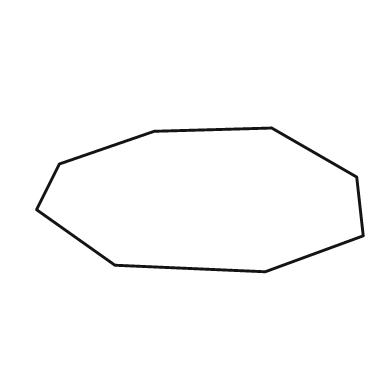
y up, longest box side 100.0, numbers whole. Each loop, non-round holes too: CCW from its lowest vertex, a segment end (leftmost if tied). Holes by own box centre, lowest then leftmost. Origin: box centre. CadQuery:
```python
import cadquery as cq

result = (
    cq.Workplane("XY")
    .moveTo(20.0, -22.0)
    .lineTo(50.0, -11.0)
    .lineTo(48.0, 7.0)
    .lineTo(22.0, 22.0)
    .lineTo(-14.0, 21.0)
    .lineTo(-43.0, 11.0)
    .lineTo(-50.0, -3.0)
    .lineTo(-26.0, -20.0)
    .close()
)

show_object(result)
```